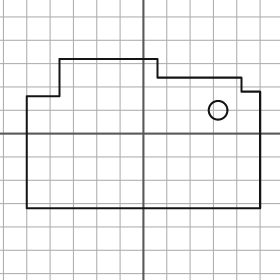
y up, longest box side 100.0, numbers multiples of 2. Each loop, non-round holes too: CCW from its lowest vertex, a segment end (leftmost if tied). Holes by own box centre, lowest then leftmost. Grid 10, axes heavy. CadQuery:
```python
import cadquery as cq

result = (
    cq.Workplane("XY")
    .moveTo(-50.0, -32.0)
    .lineTo(50.0, -32.0)
    .lineTo(50.0, 18.0)
    .lineTo(42.0, 18.0)
    .lineTo(42.0, 24.0)
    .lineTo(6.0, 24.0)
    .lineTo(6.0, 32.0)
    .lineTo(-36.0, 32.0)
    .lineTo(-36.0, 16.0)
    .lineTo(-50.0, 16.0)
    .close()
    .moveTo(32.0, 10.0)
    .circle(4.0)
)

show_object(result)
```